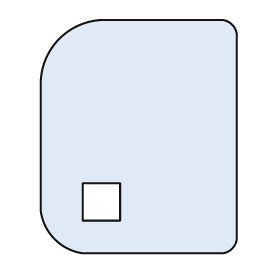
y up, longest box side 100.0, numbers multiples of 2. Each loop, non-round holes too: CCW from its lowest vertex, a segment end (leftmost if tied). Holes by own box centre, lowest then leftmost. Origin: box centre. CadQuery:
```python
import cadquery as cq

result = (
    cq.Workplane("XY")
    .moveTo(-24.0, -50.0)
    .lineTo(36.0, -50.0)
    .threePointArc((40.0, -48.0), (42.0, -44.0))
    .lineTo(42.0, 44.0)
    .threePointArc((40.0, 48.0), (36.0, 50.0))
    .lineTo(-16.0, 50.0)
    .threePointArc((-34.0, 42.0), (-42.0, 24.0))
    .lineTo(-42.0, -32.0)
    .threePointArc((-36.0, -44.0), (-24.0, -50.0))
    .close()
    .moveTo(-24.0, -36.0)
    .lineTo(-8.0, -36.0)
    .lineTo(-8.0, -20.0)
    .lineTo(-24.0, -20.0)
    .close()
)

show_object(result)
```